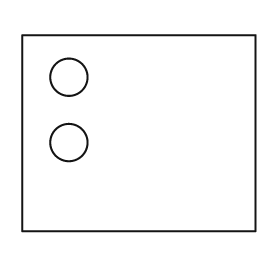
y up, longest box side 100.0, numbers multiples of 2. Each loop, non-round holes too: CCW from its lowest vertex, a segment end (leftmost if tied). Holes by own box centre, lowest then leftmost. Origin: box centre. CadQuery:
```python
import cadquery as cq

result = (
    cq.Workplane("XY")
    .moveTo(-50.0, -42.0)
    .lineTo(50.0, -42.0)
    .lineTo(50.0, 42.0)
    .lineTo(-50.0, 42.0)
    .close()
    .moveTo(-30.0, -4.0)
    .circle(8.0)
    .moveTo(-30.0, 24.0)
    .circle(8.0)
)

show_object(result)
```